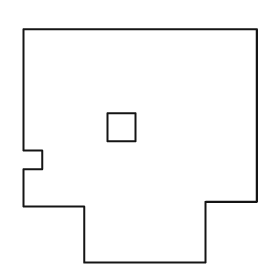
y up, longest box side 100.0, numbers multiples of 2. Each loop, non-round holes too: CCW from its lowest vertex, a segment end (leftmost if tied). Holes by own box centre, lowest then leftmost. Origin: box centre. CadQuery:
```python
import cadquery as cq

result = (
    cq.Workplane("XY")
    .moveTo(-24.0, -50.0)
    .lineTo(28.0, -50.0)
    .lineTo(28.0, -24.0)
    .lineTo(50.0, -24.0)
    .lineTo(50.0, 50.0)
    .lineTo(-50.0, 50.0)
    .lineTo(-50.0, -2.0)
    .lineTo(-42.0, -2.0)
    .lineTo(-42.0, -10.0)
    .lineTo(-50.0, -10.0)
    .lineTo(-50.0, -26.0)
    .lineTo(-24.0, -26.0)
    .close()
    .moveTo(-14.0, 2.0)
    .lineTo(-2.0, 2.0)
    .lineTo(-2.0, 14.0)
    .lineTo(-14.0, 14.0)
    .close()
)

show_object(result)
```